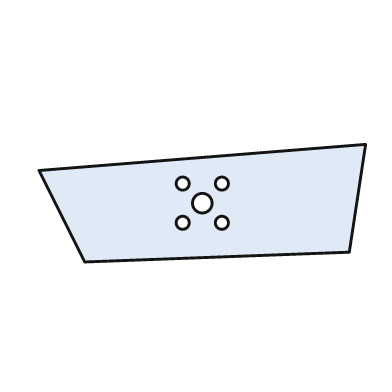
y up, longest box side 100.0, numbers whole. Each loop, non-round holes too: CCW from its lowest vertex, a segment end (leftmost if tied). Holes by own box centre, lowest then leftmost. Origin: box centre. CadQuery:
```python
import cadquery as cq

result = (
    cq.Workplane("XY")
    .moveTo(-36.0, -18.0)
    .lineTo(45.0, -15.0)
    .lineTo(50.0, 18.0)
    .lineTo(-50.0, 10.0)
    .close()
    .moveTo(-6.0, -6.0)
    .circle(2.0)
    .moveTo(6.0, -6.0)
    .circle(2.0)
    .moveTo(0.0, 0.0)
    .circle(3.0)
    .moveTo(-6.0, 6.0)
    .circle(2.0)
    .moveTo(6.0, 6.0)
    .circle(2.0)
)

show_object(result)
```